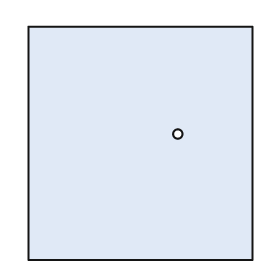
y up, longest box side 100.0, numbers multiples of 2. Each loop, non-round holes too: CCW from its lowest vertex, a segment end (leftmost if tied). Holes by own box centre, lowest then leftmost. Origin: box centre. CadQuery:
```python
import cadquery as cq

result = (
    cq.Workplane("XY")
    .moveTo(-48.0, -50.0)
    .lineTo(48.0, -50.0)
    .lineTo(48.0, 50.0)
    .lineTo(-48.0, 50.0)
    .close()
    .moveTo(16.0, 4.0)
    .circle(2.0)
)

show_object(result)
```